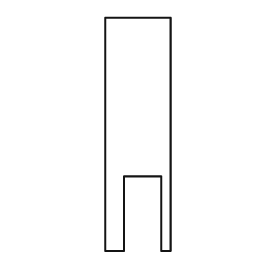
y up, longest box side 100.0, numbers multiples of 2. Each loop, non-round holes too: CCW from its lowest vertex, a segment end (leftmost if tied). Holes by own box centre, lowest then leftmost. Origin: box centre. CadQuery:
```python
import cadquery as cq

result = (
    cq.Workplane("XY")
    .moveTo(-14.0, -50.0)
    .lineTo(-6.0, -50.0)
    .lineTo(-6.0, -18.0)
    .lineTo(10.0, -18.0)
    .lineTo(10.0, -50.0)
    .lineTo(14.0, -50.0)
    .lineTo(14.0, 50.0)
    .lineTo(-14.0, 50.0)
    .close()
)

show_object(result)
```